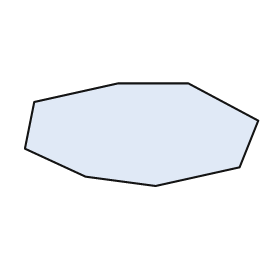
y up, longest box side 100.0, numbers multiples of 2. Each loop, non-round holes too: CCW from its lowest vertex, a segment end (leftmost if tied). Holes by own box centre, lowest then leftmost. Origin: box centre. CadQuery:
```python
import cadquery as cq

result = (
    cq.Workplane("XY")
    .moveTo(6.0, -22.0)
    .lineTo(42.0, -14.0)
    .lineTo(50.0, 6.0)
    .lineTo(20.0, 22.0)
    .lineTo(-10.0, 22.0)
    .lineTo(-46.0, 14.0)
    .lineTo(-50.0, -6.0)
    .lineTo(-24.0, -18.0)
    .close()
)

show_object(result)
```